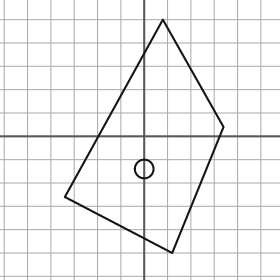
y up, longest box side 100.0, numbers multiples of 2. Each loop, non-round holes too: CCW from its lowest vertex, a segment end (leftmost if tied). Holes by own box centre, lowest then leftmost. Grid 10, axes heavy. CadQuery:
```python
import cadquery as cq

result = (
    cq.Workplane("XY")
    .moveTo(12.0, -50.0)
    .lineTo(34.0, 4.0)
    .lineTo(8.0, 50.0)
    .lineTo(-34.0, -26.0)
    .close()
    .moveTo(0.0, -14.0)
    .circle(4.0)
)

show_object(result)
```